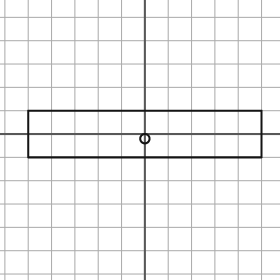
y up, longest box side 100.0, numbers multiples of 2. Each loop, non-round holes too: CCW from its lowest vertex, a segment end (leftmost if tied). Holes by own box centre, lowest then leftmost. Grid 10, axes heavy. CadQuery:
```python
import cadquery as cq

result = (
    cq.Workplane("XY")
    .moveTo(-50.0, -10.0)
    .lineTo(50.0, -10.0)
    .lineTo(50.0, 10.0)
    .lineTo(-50.0, 10.0)
    .close()
    .moveTo(0.0, -2.0)
    .circle(2.0)
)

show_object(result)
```